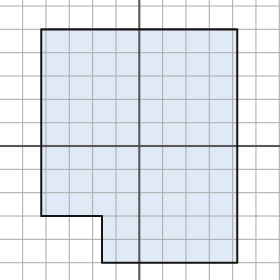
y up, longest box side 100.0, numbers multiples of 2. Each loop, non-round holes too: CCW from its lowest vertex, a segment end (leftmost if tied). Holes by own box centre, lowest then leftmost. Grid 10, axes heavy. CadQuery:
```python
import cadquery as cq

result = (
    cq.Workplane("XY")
    .moveTo(-16.0, -50.0)
    .lineTo(42.0, -50.0)
    .lineTo(42.0, 50.0)
    .lineTo(-42.0, 50.0)
    .lineTo(-42.0, -30.0)
    .lineTo(-16.0, -30.0)
    .close()
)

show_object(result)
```